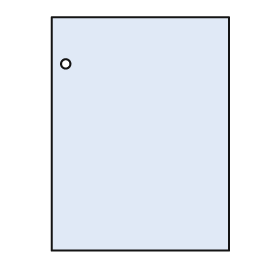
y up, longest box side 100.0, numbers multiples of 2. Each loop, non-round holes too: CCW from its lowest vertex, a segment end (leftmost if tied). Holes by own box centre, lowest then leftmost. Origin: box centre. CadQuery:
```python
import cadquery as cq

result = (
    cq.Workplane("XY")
    .moveTo(-38.0, -50.0)
    .lineTo(38.0, -50.0)
    .lineTo(38.0, 50.0)
    .lineTo(-38.0, 50.0)
    .close()
    .moveTo(-32.0, 30.0)
    .circle(2.0)
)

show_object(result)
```